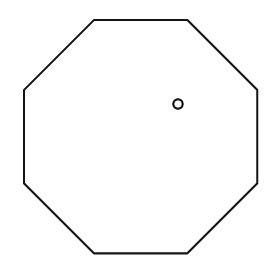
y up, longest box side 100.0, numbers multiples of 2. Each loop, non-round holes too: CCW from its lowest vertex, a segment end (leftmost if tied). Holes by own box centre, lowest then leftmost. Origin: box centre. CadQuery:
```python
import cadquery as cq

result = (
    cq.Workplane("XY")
    .moveTo(-20.0, -50.0)
    .lineTo(20.0, -50.0)
    .lineTo(50.0, -20.0)
    .lineTo(50.0, 20.0)
    .lineTo(20.0, 50.0)
    .lineTo(-20.0, 50.0)
    .lineTo(-50.0, 20.0)
    .lineTo(-50.0, -20.0)
    .close()
    .moveTo(16.0, 14.0)
    .circle(2.0)
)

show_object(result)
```